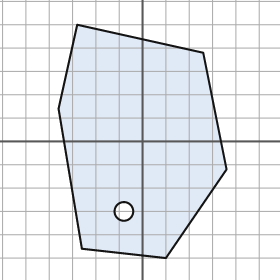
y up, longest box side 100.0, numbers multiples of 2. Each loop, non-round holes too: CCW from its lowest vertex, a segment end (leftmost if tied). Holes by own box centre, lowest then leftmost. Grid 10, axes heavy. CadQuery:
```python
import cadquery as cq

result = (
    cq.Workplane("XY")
    .moveTo(10.0, -50.0)
    .lineTo(36.0, -12.0)
    .lineTo(26.0, 38.0)
    .lineTo(-28.0, 50.0)
    .lineTo(-36.0, 14.0)
    .lineTo(-26.0, -46.0)
    .close()
    .moveTo(-8.0, -30.0)
    .circle(4.0)
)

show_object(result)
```